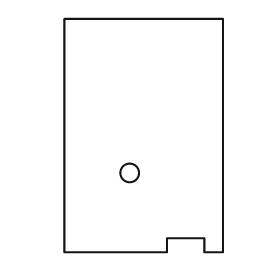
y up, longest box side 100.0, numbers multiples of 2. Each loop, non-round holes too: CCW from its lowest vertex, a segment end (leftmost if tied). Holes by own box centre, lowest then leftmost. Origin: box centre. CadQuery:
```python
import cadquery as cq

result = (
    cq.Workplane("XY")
    .moveTo(-34.0, -50.0)
    .lineTo(10.0, -50.0)
    .lineTo(10.0, -44.0)
    .lineTo(26.0, -44.0)
    .lineTo(26.0, -50.0)
    .lineTo(34.0, -50.0)
    .lineTo(34.0, 50.0)
    .lineTo(-34.0, 50.0)
    .close()
    .moveTo(-6.0, -16.0)
    .circle(4.0)
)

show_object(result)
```